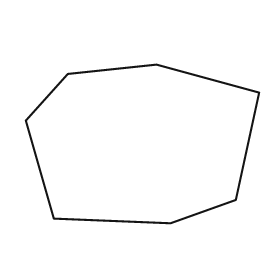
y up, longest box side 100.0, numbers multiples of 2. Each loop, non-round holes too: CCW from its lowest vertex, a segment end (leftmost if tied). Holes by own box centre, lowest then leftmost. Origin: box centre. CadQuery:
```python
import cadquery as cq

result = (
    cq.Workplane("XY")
    .moveTo(12.0, -34.0)
    .lineTo(40.0, -24.0)
    .lineTo(50.0, 22.0)
    .lineTo(6.0, 34.0)
    .lineTo(-32.0, 30.0)
    .lineTo(-50.0, 10.0)
    .lineTo(-38.0, -32.0)
    .close()
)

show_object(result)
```